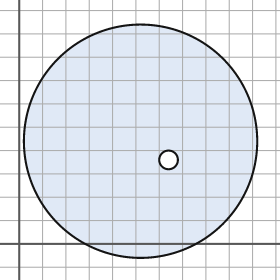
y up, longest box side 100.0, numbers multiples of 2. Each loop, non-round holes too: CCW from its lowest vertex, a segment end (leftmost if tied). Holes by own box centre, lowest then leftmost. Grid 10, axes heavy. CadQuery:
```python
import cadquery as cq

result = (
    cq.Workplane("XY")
    .moveTo(52.0, 44.0)
    .circle(50.0)
    .moveTo(64.0, 36.0)
    .circle(4.0)
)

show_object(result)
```